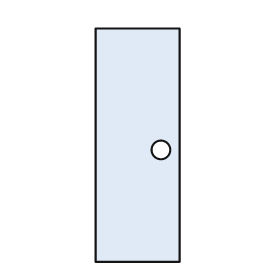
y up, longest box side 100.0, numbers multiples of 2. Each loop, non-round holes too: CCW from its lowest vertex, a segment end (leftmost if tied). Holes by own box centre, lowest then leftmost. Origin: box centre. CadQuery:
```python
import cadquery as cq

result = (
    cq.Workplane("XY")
    .moveTo(-18.0, -50.0)
    .lineTo(18.0, -50.0)
    .lineTo(18.0, 50.0)
    .lineTo(-18.0, 50.0)
    .close()
    .moveTo(10.0, -2.0)
    .circle(4.0)
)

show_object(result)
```